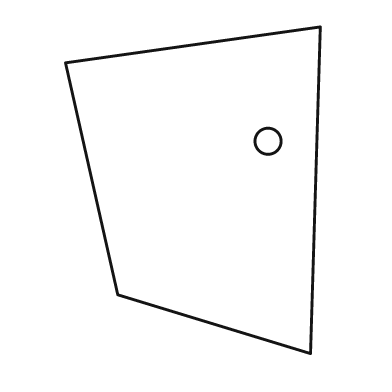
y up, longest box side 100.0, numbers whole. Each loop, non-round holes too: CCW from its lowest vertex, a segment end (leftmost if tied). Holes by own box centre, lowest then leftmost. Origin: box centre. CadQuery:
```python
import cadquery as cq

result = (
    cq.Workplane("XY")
    .moveTo(36.0, -50.0)
    .lineTo(39.0, 50.0)
    .lineTo(-39.0, 39.0)
    .lineTo(-23.0, -32.0)
    .close()
    .moveTo(23.0, 15.0)
    .circle(4.0)
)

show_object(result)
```